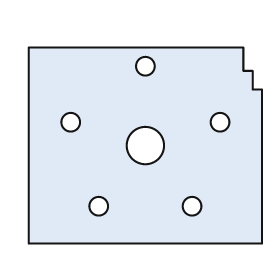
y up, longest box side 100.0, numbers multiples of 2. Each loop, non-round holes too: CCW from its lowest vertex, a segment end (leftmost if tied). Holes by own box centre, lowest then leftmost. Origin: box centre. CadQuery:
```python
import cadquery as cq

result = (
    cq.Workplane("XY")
    .moveTo(-50.0, -42.0)
    .lineTo(50.0, -42.0)
    .lineTo(50.0, 24.0)
    .lineTo(46.0, 24.0)
    .lineTo(46.0, 32.0)
    .lineTo(42.0, 32.0)
    .lineTo(42.0, 42.0)
    .lineTo(-50.0, 42.0)
    .close()
    .moveTo(-20.0, -26.0)
    .circle(4.0)
    .moveTo(20.0, -26.0)
    .circle(4.0)
    .moveTo(0.0, 0.0)
    .circle(8.0)
    .moveTo(-32.0, 10.0)
    .circle(4.0)
    .moveTo(32.0, 10.0)
    .circle(4.0)
    .moveTo(0.0, 34.0)
    .circle(4.0)
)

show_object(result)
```